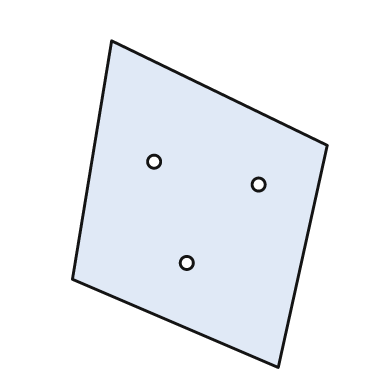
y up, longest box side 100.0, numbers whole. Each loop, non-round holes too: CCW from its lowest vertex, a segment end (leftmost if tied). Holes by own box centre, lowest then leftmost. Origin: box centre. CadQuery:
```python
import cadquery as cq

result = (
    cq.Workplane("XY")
    .moveTo(24.0, -50.0)
    .lineTo(39.0, 18.0)
    .lineTo(-27.0, 50.0)
    .lineTo(-39.0, -23.0)
    .close()
    .moveTo(-4.0, -18.0)
    .circle(2.0)
    .moveTo(18.0, 6.0)
    .circle(2.0)
    .moveTo(-14.0, 13.0)
    .circle(2.0)
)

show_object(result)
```